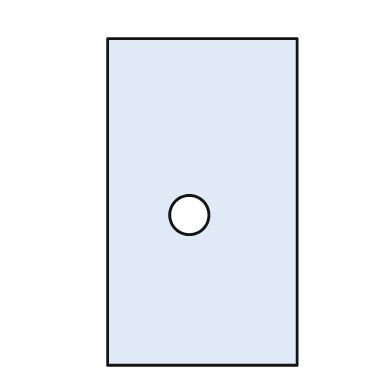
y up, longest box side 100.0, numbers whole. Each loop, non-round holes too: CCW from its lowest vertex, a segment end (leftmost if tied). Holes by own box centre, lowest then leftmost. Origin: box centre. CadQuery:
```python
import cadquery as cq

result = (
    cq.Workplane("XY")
    .moveTo(-29.0, -50.0)
    .lineTo(29.0, -50.0)
    .lineTo(29.0, 50.0)
    .lineTo(-29.0, 50.0)
    .close()
    .moveTo(-4.0, -4.0)
    .circle(6.0)
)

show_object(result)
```